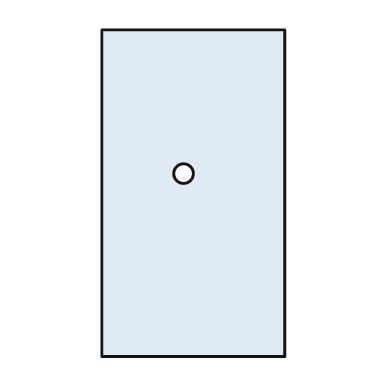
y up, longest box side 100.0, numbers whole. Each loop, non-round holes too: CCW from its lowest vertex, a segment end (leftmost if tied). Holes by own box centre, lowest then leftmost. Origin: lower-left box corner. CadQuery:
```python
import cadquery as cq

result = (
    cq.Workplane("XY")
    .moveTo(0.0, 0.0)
    .lineTo(56.0, 0.0)
    .lineTo(56.0, 100.0)
    .lineTo(0.0, 100.0)
    .close()
    .moveTo(25.0, 56.0)
    .circle(3.0)
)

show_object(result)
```